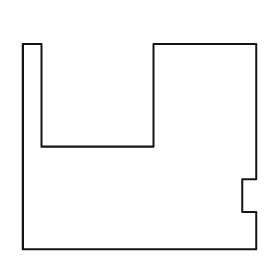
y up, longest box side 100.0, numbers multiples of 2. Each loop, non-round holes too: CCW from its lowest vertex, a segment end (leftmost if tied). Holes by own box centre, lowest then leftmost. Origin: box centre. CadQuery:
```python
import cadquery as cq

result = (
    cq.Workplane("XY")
    .moveTo(-50.0, -44.0)
    .lineTo(50.0, -44.0)
    .lineTo(50.0, -28.0)
    .lineTo(44.0, -28.0)
    .lineTo(44.0, -14.0)
    .lineTo(50.0, -14.0)
    .lineTo(50.0, 44.0)
    .lineTo(6.0, 44.0)
    .lineTo(6.0, 0.0)
    .lineTo(-42.0, 0.0)
    .lineTo(-42.0, 44.0)
    .lineTo(-50.0, 44.0)
    .close()
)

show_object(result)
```